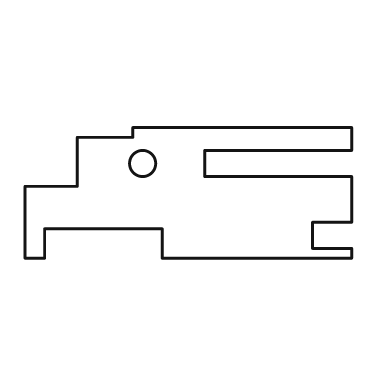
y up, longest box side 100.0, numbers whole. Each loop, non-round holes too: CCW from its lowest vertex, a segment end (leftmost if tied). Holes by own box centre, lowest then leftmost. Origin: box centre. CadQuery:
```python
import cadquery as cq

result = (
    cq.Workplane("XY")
    .moveTo(-50.0, -20.0)
    .lineTo(-44.0, -20.0)
    .lineTo(-44.0, -11.0)
    .lineTo(-8.0, -11.0)
    .lineTo(-8.0, -20.0)
    .lineTo(50.0, -20.0)
    .lineTo(50.0, -17.0)
    .lineTo(38.0, -17.0)
    .lineTo(38.0, -9.0)
    .lineTo(50.0, -9.0)
    .lineTo(50.0, 5.0)
    .lineTo(5.0, 5.0)
    .lineTo(5.0, 13.0)
    .lineTo(50.0, 13.0)
    .lineTo(50.0, 20.0)
    .lineTo(-17.0, 20.0)
    .lineTo(-17.0, 17.0)
    .lineTo(-34.0, 17.0)
    .lineTo(-34.0, 2.0)
    .lineTo(-50.0, 2.0)
    .close()
    .moveTo(-14.0, 9.0)
    .circle(4.0)
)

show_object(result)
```